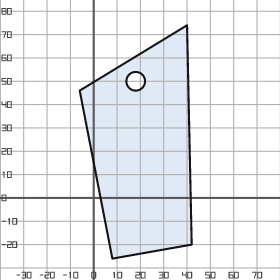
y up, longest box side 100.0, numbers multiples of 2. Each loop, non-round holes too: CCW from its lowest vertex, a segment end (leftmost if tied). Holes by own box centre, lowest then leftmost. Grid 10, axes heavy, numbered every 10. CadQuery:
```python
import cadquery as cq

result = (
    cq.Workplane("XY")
    .moveTo(8.0, -26.0)
    .lineTo(42.0, -20.0)
    .lineTo(40.0, 74.0)
    .lineTo(-6.0, 46.0)
    .close()
    .moveTo(18.0, 50.0)
    .circle(4.0)
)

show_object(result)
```